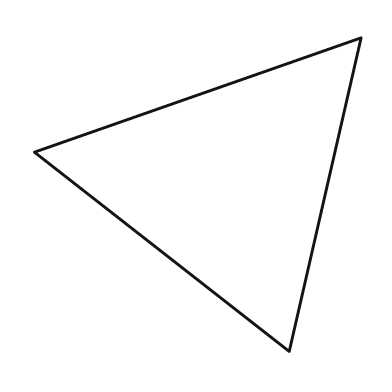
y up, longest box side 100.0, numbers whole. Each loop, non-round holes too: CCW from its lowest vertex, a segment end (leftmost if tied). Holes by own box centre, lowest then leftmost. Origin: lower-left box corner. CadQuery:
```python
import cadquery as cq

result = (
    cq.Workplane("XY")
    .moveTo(78.0, 0.0)
    .lineTo(100.0, 96.0)
    .lineTo(0.0, 61.0)
    .close()
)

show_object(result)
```